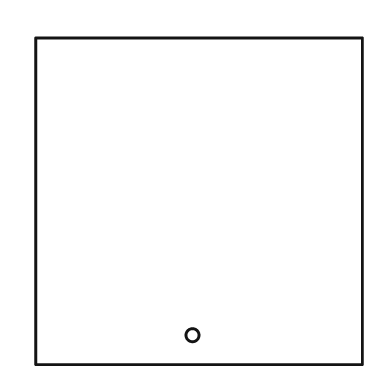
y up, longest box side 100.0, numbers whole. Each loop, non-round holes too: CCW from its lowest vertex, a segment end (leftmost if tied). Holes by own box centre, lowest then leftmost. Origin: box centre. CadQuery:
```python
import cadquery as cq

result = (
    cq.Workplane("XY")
    .moveTo(-50.0, -50.0)
    .lineTo(50.0, -50.0)
    .lineTo(50.0, 50.0)
    .lineTo(-50.0, 50.0)
    .close()
    .moveTo(-2.0, -41.0)
    .circle(2.0)
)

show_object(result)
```